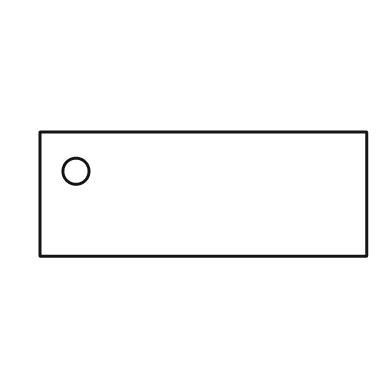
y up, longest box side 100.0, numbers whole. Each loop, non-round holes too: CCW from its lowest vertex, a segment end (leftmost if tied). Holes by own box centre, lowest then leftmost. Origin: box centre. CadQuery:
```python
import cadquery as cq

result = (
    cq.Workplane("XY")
    .moveTo(-50.0, -19.0)
    .lineTo(50.0, -19.0)
    .lineTo(50.0, 19.0)
    .lineTo(-50.0, 19.0)
    .close()
    .moveTo(-39.0, 7.0)
    .circle(4.0)
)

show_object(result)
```